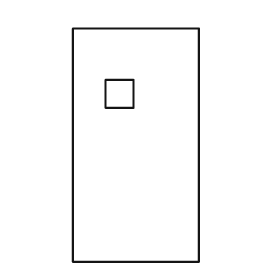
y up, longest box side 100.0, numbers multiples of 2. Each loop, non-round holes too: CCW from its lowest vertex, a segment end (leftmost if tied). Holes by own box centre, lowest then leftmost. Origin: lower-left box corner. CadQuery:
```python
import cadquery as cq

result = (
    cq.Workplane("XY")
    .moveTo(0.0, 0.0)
    .lineTo(54.0, 0.0)
    .lineTo(54.0, 100.0)
    .lineTo(0.0, 100.0)
    .close()
    .moveTo(14.0, 66.0)
    .lineTo(26.0, 66.0)
    .lineTo(26.0, 78.0)
    .lineTo(14.0, 78.0)
    .close()
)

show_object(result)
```